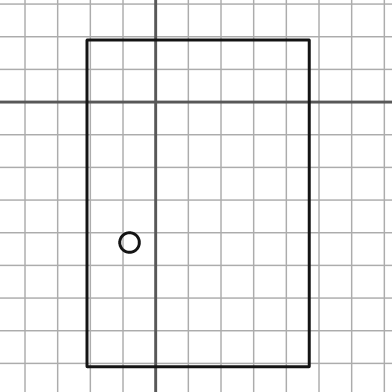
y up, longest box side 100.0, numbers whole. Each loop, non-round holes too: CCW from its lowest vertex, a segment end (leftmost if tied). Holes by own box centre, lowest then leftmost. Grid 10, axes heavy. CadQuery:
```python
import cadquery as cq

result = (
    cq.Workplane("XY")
    .moveTo(-21.0, -81.0)
    .lineTo(47.0, -81.0)
    .lineTo(47.0, 19.0)
    .lineTo(-21.0, 19.0)
    .close()
    .moveTo(-8.0, -43.0)
    .circle(3.0)
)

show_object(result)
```